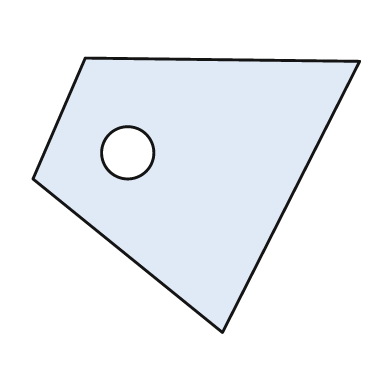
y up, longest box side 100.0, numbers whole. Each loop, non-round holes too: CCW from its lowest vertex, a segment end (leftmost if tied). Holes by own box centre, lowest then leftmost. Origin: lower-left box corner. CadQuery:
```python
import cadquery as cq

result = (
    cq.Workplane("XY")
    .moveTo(58.0, 0.0)
    .lineTo(100.0, 83.0)
    .lineTo(16.0, 84.0)
    .lineTo(0.0, 47.0)
    .close()
    .moveTo(29.0, 55.0)
    .circle(8.0)
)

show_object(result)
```